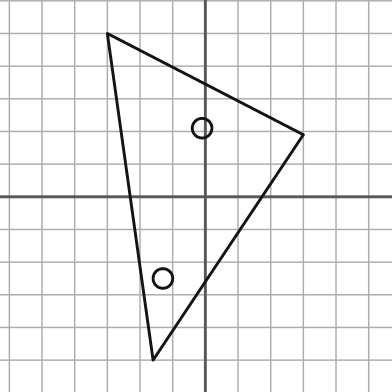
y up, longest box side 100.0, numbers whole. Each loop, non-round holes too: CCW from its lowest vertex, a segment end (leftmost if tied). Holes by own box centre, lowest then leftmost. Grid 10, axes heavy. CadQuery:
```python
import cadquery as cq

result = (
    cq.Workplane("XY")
    .moveTo(-16.0, -50.0)
    .lineTo(30.0, 19.0)
    .lineTo(-30.0, 50.0)
    .close()
    .moveTo(-13.0, -25.0)
    .circle(3.0)
    .moveTo(-1.0, 21.0)
    .circle(3.0)
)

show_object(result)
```